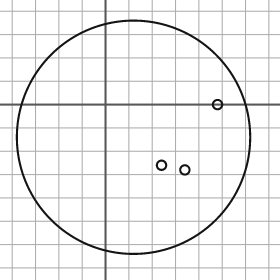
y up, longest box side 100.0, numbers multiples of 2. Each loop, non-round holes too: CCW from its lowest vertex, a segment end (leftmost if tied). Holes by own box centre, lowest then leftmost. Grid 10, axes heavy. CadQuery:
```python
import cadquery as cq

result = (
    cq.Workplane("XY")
    .moveTo(12.0, -14.0)
    .circle(50.0)
    .moveTo(34.0, -28.0)
    .circle(2.0)
    .moveTo(24.0, -26.0)
    .circle(2.0)
    .moveTo(48.0, 0.0)
    .circle(2.0)
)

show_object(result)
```